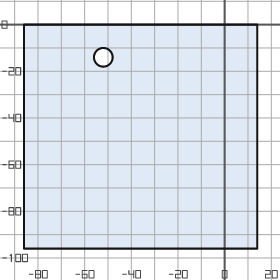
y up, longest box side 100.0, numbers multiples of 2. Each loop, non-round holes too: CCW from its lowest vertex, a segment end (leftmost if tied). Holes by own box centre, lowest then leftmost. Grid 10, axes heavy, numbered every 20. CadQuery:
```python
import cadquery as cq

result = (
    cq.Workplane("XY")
    .moveTo(-86.0, -96.0)
    .lineTo(14.0, -96.0)
    .lineTo(14.0, 0.0)
    .lineTo(-86.0, 0.0)
    .close()
    .moveTo(-52.0, -14.0)
    .circle(4.0)
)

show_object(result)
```